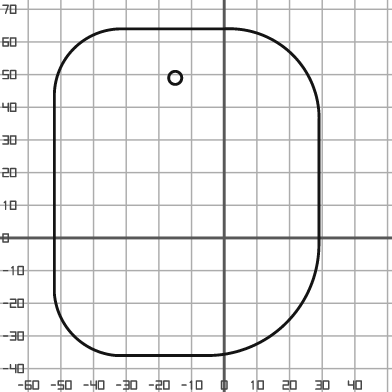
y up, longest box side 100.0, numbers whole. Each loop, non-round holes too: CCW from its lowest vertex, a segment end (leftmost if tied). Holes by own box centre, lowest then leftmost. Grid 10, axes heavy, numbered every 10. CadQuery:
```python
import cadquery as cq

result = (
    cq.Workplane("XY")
    .moveTo(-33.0, -36.0)
    .lineTo(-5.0, -36.0)
    .threePointArc((19.0, -26.0), (29.0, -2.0))
    .lineTo(29.0, 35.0)
    .threePointArc((21.0, 56.0), (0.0, 64.0))
    .lineTo(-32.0, 64.0)
    .threePointArc((-46.0, 58.0), (-52.0, 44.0))
    .lineTo(-52.0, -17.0)
    .threePointArc((-46.0, -30.0), (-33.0, -36.0))
    .close()
    .moveTo(-15.0, 49.0)
    .circle(2.0)
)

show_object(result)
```